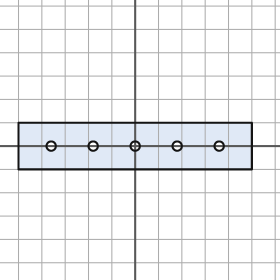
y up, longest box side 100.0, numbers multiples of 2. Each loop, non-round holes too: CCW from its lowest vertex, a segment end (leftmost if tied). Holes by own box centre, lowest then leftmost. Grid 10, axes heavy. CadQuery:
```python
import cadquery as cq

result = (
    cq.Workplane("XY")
    .moveTo(-50.0, -10.0)
    .lineTo(50.0, -10.0)
    .lineTo(50.0, 10.0)
    .lineTo(-50.0, 10.0)
    .close()
    .moveTo(-36.0, 0.0)
    .circle(2.0)
    .moveTo(-18.0, 0.0)
    .circle(2.0)
    .moveTo(0.0, 0.0)
    .circle(2.0)
    .moveTo(18.0, 0.0)
    .circle(2.0)
    .moveTo(36.0, 0.0)
    .circle(2.0)
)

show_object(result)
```